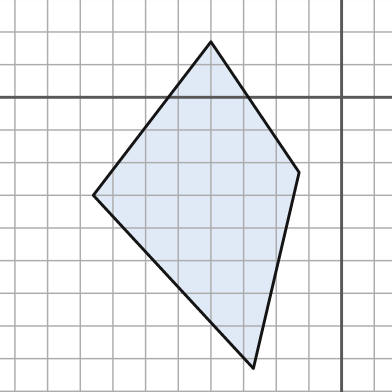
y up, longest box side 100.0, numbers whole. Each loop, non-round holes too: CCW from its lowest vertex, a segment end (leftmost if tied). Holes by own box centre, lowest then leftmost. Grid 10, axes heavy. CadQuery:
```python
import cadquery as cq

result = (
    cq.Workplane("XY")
    .moveTo(-27.0, -83.0)
    .lineTo(-13.0, -23.0)
    .lineTo(-40.0, 17.0)
    .lineTo(-76.0, -30.0)
    .close()
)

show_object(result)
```